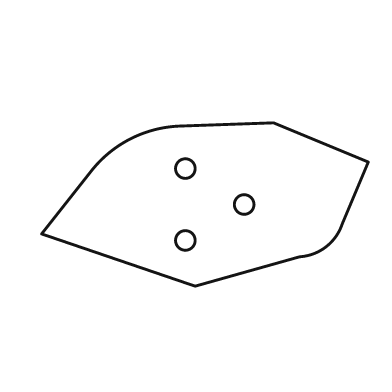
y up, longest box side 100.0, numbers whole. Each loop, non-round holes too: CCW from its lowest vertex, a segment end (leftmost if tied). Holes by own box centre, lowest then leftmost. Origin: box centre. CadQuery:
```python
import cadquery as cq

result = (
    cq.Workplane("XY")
    .moveTo(-3.0, -25.0)
    .lineTo(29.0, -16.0)
    .threePointArc((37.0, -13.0), (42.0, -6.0))
    .lineTo(50.0, 13.0)
    .lineTo(21.0, 25.0)
    .lineTo(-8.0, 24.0)
    .threePointArc((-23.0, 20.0), (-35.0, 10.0))
    .lineTo(-50.0, -9.0)
    .close()
    .moveTo(-6.0, -11.0)
    .circle(3.0)
    .moveTo(12.0, 0.0)
    .circle(3.0)
    .moveTo(-6.0, 11.0)
    .circle(3.0)
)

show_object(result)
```